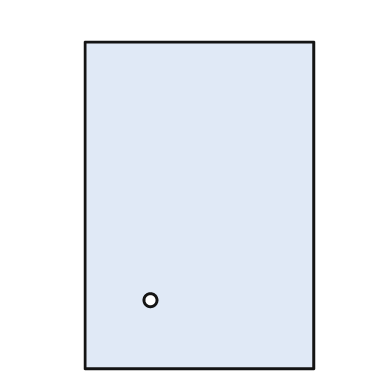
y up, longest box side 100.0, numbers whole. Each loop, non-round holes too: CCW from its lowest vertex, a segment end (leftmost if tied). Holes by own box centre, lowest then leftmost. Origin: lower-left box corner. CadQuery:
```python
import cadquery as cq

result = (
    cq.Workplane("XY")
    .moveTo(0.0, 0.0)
    .lineTo(70.0, 0.0)
    .lineTo(70.0, 100.0)
    .lineTo(0.0, 100.0)
    .close()
    .moveTo(20.0, 21.0)
    .circle(2.0)
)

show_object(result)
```